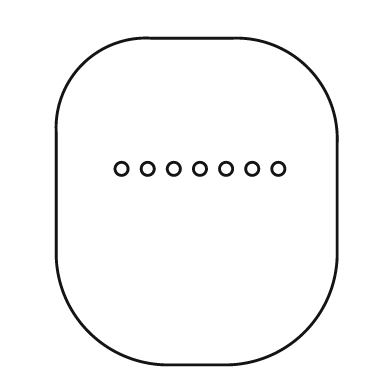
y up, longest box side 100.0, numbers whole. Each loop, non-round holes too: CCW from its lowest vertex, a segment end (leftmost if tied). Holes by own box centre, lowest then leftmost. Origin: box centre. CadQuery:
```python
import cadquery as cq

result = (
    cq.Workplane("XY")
    .moveTo(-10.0, -50.0)
    .lineTo(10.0, -50.0)
    .threePointArc((33.0, -40.0), (43.0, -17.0))
    .lineTo(43.0, 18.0)
    .threePointArc((34.0, 41.0), (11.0, 50.0))
    .lineTo(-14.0, 50.0)
    .threePointArc((-35.0, 42.0), (-43.0, 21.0))
    .lineTo(-43.0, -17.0)
    .threePointArc((-33.0, -40.0), (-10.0, -50.0))
    .close()
    .moveTo(-23.0, 10.0)
    .circle(2.0)
    .moveTo(-15.0, 10.0)
    .circle(2.0)
    .moveTo(-7.0, 10.0)
    .circle(2.0)
    .moveTo(1.0, 10.0)
    .circle(2.0)
    .moveTo(9.0, 10.0)
    .circle(2.0)
    .moveTo(17.0, 10.0)
    .circle(2.0)
    .moveTo(25.0, 10.0)
    .circle(2.0)
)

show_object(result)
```